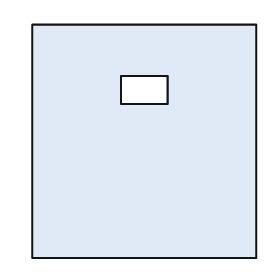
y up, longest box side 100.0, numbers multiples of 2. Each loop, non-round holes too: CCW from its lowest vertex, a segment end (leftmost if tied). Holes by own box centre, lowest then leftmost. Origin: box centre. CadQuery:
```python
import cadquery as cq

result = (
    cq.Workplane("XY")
    .moveTo(-48.0, -50.0)
    .lineTo(48.0, -50.0)
    .lineTo(48.0, 50.0)
    .lineTo(-48.0, 50.0)
    .close()
    .moveTo(-10.0, 16.0)
    .lineTo(10.0, 16.0)
    .lineTo(10.0, 28.0)
    .lineTo(-10.0, 28.0)
    .close()
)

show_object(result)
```